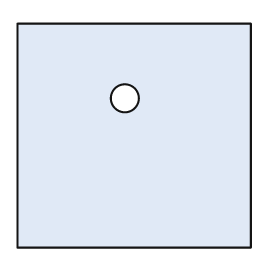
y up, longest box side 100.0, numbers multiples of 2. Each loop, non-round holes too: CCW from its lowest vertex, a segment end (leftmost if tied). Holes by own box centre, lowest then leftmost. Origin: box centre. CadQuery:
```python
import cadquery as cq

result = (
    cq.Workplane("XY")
    .moveTo(-50.0, -48.0)
    .lineTo(50.0, -48.0)
    .lineTo(50.0, 48.0)
    .lineTo(-50.0, 48.0)
    .close()
    .moveTo(-4.0, 16.0)
    .circle(6.0)
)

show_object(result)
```